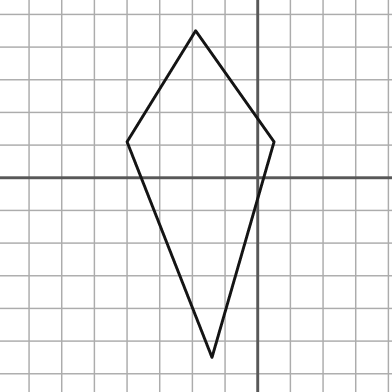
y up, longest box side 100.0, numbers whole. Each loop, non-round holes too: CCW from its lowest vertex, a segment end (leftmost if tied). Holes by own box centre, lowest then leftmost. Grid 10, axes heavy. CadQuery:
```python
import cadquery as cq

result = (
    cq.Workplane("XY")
    .moveTo(-14.0, -55.0)
    .lineTo(5.0, 11.0)
    .lineTo(-19.0, 45.0)
    .lineTo(-40.0, 11.0)
    .close()
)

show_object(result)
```